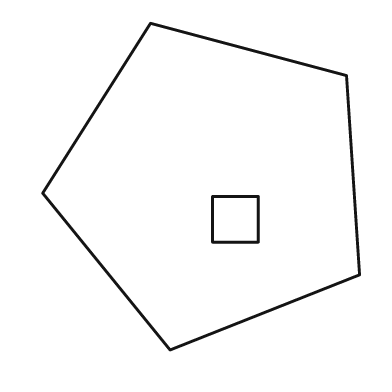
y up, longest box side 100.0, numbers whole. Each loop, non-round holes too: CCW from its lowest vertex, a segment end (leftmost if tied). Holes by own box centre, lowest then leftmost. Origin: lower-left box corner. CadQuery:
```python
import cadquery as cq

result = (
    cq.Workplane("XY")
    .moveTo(39.0, 0.0)
    .lineTo(97.0, 23.0)
    .lineTo(93.0, 84.0)
    .lineTo(33.0, 100.0)
    .lineTo(0.0, 48.0)
    .close()
    .moveTo(52.0, 33.0)
    .lineTo(66.0, 33.0)
    .lineTo(66.0, 47.0)
    .lineTo(52.0, 47.0)
    .close()
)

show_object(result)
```